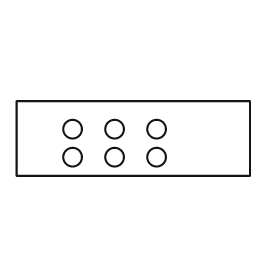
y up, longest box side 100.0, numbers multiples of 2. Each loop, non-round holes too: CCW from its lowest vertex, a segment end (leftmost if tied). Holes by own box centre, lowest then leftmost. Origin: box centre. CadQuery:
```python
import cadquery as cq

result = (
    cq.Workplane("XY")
    .moveTo(-50.0, -16.0)
    .lineTo(50.0, -16.0)
    .lineTo(50.0, 16.0)
    .lineTo(-50.0, 16.0)
    .close()
    .moveTo(-26.0, -8.0)
    .circle(4.0)
    .moveTo(-8.0, -8.0)
    .circle(4.0)
    .moveTo(10.0, -8.0)
    .circle(4.0)
    .moveTo(-26.0, 4.0)
    .circle(4.0)
    .moveTo(-8.0, 4.0)
    .circle(4.0)
    .moveTo(10.0, 4.0)
    .circle(4.0)
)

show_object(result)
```